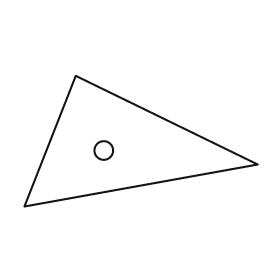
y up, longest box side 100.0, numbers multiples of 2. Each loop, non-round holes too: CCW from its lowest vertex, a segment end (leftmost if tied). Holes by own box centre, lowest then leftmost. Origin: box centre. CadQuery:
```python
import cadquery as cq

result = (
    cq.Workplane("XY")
    .moveTo(-50.0, -28.0)
    .lineTo(50.0, -10.0)
    .lineTo(-28.0, 28.0)
    .close()
    .moveTo(-16.0, -4.0)
    .circle(4.0)
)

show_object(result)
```